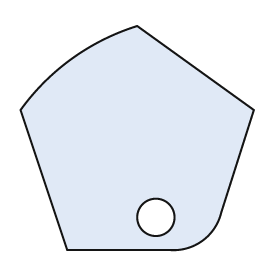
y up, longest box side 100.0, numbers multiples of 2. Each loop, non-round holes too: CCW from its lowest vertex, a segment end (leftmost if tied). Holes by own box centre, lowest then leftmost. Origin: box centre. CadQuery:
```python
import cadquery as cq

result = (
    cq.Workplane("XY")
    .moveTo(-30.0, -48.0)
    .lineTo(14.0, -48.0)
    .threePointArc((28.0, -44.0), (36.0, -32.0))
    .lineTo(50.0, 12.0)
    .lineTo(0.0, 48.0)
    .threePointArc((-28.0, 34.0), (-50.0, 12.0))
    .close()
    .moveTo(8.0, -34.0)
    .circle(8.0)
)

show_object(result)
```